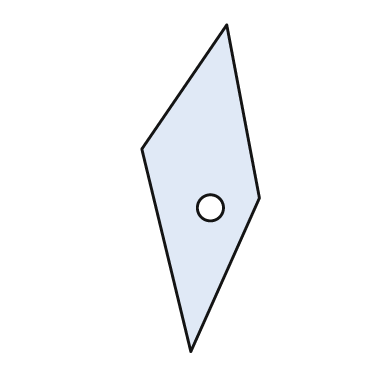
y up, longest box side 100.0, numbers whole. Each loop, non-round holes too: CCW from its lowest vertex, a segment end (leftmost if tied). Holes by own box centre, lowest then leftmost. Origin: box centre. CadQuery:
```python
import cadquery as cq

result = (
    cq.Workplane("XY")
    .moveTo(-3.0, -50.0)
    .lineTo(18.0, -3.0)
    .lineTo(8.0, 50.0)
    .lineTo(-18.0, 12.0)
    .close()
    .moveTo(3.0, -6.0)
    .circle(4.0)
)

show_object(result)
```